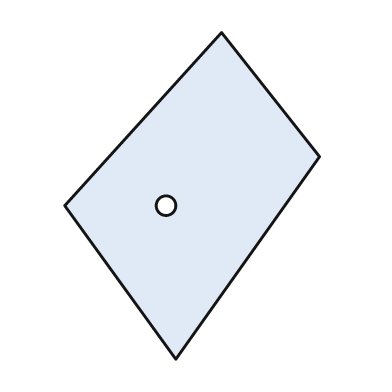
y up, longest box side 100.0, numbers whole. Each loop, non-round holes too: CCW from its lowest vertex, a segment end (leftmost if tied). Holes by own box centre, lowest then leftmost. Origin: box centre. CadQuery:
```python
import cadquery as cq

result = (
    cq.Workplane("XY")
    .moveTo(-5.0, -50.0)
    .lineTo(39.0, 12.0)
    .lineTo(9.0, 50.0)
    .lineTo(-39.0, -3.0)
    .close()
    .moveTo(-8.0, -3.0)
    .circle(3.0)
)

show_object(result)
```